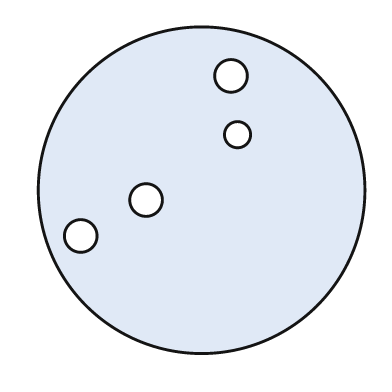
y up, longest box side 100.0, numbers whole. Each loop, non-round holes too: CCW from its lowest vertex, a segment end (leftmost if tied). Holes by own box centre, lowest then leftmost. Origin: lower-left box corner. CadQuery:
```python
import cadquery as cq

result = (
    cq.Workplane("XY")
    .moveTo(50.0, 50.0)
    .circle(50.0)
    .moveTo(13.0, 36.0)
    .circle(5.0)
    .moveTo(33.0, 47.0)
    .circle(5.0)
    .moveTo(61.0, 67.0)
    .circle(4.0)
    .moveTo(59.0, 85.0)
    .circle(5.0)
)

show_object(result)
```